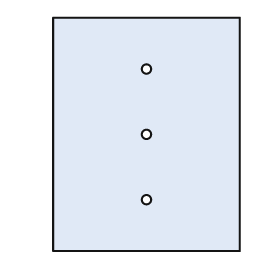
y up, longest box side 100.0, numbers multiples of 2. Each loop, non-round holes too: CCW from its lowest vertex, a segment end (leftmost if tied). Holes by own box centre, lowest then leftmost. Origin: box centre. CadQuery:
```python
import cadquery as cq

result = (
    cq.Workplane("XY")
    .moveTo(-40.0, -50.0)
    .lineTo(40.0, -50.0)
    .lineTo(40.0, 50.0)
    .lineTo(-40.0, 50.0)
    .close()
    .moveTo(0.0, -28.0)
    .circle(2.0)
    .moveTo(0.0, 0.0)
    .circle(2.0)
    .moveTo(0.0, 28.0)
    .circle(2.0)
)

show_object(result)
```